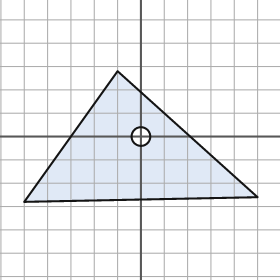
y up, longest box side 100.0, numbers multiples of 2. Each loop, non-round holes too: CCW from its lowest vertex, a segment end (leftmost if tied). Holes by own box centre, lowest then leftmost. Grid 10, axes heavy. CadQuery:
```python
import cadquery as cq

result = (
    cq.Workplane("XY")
    .moveTo(-50.0, -28.0)
    .lineTo(50.0, -26.0)
    .lineTo(-10.0, 28.0)
    .close()
    .moveTo(0.0, 0.0)
    .circle(4.0)
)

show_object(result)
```